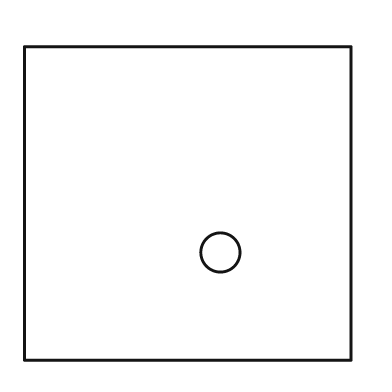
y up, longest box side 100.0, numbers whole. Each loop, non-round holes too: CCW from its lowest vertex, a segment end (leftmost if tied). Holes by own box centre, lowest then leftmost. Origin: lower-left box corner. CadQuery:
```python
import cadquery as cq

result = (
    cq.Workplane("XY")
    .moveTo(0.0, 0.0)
    .lineTo(100.0, 0.0)
    .lineTo(100.0, 96.0)
    .lineTo(0.0, 96.0)
    .close()
    .moveTo(60.0, 33.0)
    .circle(6.0)
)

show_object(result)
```